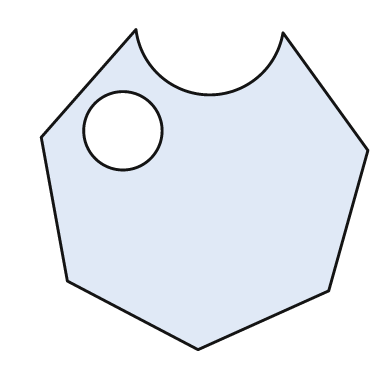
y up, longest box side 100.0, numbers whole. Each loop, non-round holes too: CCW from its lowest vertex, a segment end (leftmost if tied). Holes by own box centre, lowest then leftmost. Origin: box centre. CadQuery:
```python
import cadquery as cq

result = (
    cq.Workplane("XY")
    .moveTo(-2.0, -49.0)
    .lineTo(38.0, -31.0)
    .lineTo(50.0, 12.0)
    .lineTo(24.0, 48.0)
    .threePointArc((1.0, 29.0), (-21.0, 49.0))
    .lineTo(-50.0, 16.0)
    .lineTo(-42.0, -28.0)
    .close()
    .moveTo(-25.0, 18.0)
    .circle(12.0)
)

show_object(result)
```